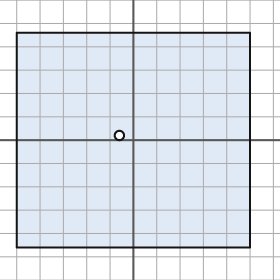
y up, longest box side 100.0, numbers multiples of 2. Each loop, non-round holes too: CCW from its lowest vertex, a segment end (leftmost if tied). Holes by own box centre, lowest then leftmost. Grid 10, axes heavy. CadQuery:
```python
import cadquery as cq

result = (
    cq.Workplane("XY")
    .moveTo(-50.0, -46.0)
    .lineTo(50.0, -46.0)
    .lineTo(50.0, 46.0)
    .lineTo(-50.0, 46.0)
    .close()
    .moveTo(-6.0, 2.0)
    .circle(2.0)
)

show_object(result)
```